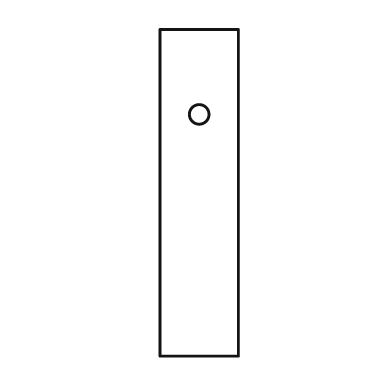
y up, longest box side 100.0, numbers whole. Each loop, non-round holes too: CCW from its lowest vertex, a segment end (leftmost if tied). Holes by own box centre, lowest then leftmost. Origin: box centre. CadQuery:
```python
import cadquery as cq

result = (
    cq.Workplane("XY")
    .moveTo(-12.0, -50.0)
    .lineTo(12.0, -50.0)
    .lineTo(12.0, 50.0)
    .lineTo(-12.0, 50.0)
    .close()
    .moveTo(0.0, 24.0)
    .circle(3.0)
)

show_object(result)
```